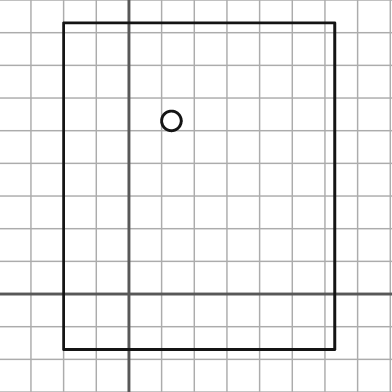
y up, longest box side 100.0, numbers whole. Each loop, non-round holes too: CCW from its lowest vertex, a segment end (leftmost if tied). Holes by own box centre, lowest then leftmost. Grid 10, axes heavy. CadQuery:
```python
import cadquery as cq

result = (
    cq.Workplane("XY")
    .moveTo(-20.0, -17.0)
    .lineTo(63.0, -17.0)
    .lineTo(63.0, 83.0)
    .lineTo(-20.0, 83.0)
    .close()
    .moveTo(13.0, 53.0)
    .circle(3.0)
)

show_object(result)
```